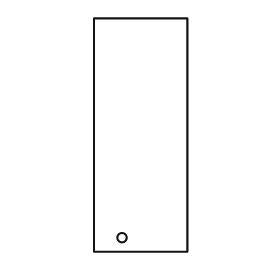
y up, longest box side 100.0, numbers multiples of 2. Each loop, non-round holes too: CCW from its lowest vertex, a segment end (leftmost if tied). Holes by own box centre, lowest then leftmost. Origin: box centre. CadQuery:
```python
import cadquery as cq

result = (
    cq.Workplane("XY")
    .moveTo(-20.0, -50.0)
    .lineTo(20.0, -50.0)
    .lineTo(20.0, 50.0)
    .lineTo(-20.0, 50.0)
    .close()
    .moveTo(-8.0, -44.0)
    .circle(2.0)
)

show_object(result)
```